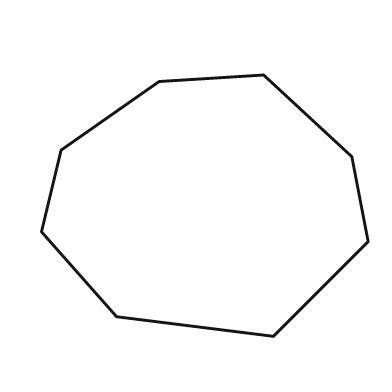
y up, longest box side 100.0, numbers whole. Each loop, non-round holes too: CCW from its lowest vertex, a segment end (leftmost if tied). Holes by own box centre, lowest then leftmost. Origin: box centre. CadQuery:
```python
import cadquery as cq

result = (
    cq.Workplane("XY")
    .moveTo(21.0, -40.0)
    .lineTo(50.0, -11.0)
    .lineTo(45.0, 15.0)
    .lineTo(18.0, 40.0)
    .lineTo(-14.0, 38.0)
    .lineTo(-44.0, 17.0)
    .lineTo(-50.0, -8.0)
    .lineTo(-27.0, -34.0)
    .close()
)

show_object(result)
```